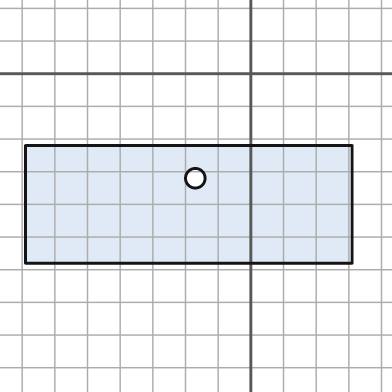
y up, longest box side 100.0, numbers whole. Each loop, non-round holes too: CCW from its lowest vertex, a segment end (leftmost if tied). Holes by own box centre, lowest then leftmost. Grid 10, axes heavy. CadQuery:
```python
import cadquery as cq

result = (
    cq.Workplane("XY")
    .moveTo(-69.0, -58.0)
    .lineTo(31.0, -58.0)
    .lineTo(31.0, -22.0)
    .lineTo(-69.0, -22.0)
    .close()
    .moveTo(-17.0, -32.0)
    .circle(3.0)
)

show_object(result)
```